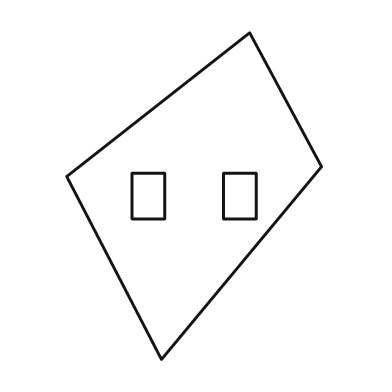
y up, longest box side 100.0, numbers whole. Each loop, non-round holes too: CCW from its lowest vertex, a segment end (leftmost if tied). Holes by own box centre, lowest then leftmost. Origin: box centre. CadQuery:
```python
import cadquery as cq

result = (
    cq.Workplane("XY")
    .moveTo(-10.0, -50.0)
    .lineTo(39.0, 9.0)
    .lineTo(17.0, 50.0)
    .lineTo(-39.0, 6.0)
    .close()
    .moveTo(-19.0, -7.0)
    .lineTo(-9.0, -7.0)
    .lineTo(-9.0, 7.0)
    .lineTo(-19.0, 7.0)
    .close()
    .moveTo(9.0, -7.0)
    .lineTo(19.0, -7.0)
    .lineTo(19.0, 7.0)
    .lineTo(9.0, 7.0)
    .close()
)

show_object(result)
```